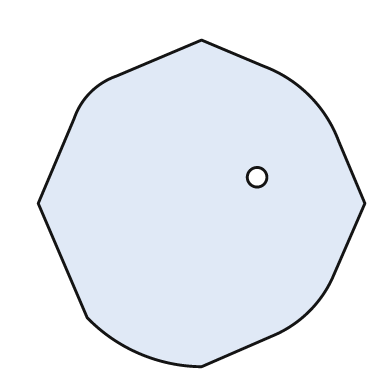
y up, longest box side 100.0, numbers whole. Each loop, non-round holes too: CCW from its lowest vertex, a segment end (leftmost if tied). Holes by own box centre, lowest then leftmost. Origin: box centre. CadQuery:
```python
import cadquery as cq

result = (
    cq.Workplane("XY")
    .moveTo(0.0, -50.0)
    .lineTo(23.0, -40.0)
    .threePointArc((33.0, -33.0), (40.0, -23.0))
    .lineTo(50.0, 0.0)
    .lineTo(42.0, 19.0)
    .threePointArc((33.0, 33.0), (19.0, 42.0))
    .lineTo(0.0, 50.0)
    .lineTo(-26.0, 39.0)
    .threePointArc((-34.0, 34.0), (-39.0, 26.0))
    .lineTo(-50.0, 0.0)
    .lineTo(-35.0, -35.0)
    .threePointArc((-19.0, -46.0), (0.0, -50.0))
    .close()
    .moveTo(17.0, 8.0)
    .circle(3.0)
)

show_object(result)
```